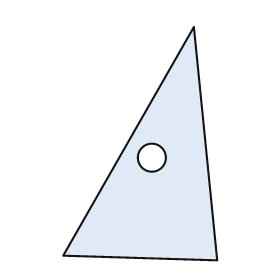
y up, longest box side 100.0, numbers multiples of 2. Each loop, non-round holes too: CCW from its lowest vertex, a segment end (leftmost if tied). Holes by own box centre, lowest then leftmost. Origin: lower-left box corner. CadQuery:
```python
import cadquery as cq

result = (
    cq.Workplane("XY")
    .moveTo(66.0, 0.0)
    .lineTo(56.0, 100.0)
    .lineTo(0.0, 2.0)
    .close()
    .moveTo(38.0, 44.0)
    .circle(6.0)
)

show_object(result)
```